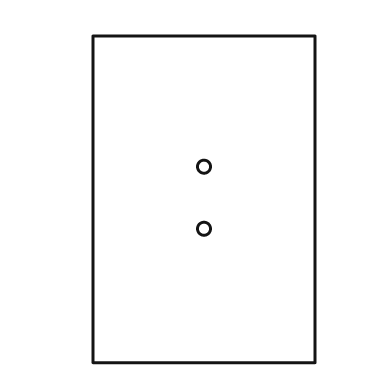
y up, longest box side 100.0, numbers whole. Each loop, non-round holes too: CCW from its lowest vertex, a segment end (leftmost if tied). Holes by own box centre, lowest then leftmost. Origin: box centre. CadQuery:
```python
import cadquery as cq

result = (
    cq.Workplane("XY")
    .moveTo(-34.0, -50.0)
    .lineTo(34.0, -50.0)
    .lineTo(34.0, 50.0)
    .lineTo(-34.0, 50.0)
    .close()
    .moveTo(0.0, -9.0)
    .circle(2.0)
    .moveTo(0.0, 10.0)
    .circle(2.0)
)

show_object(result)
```